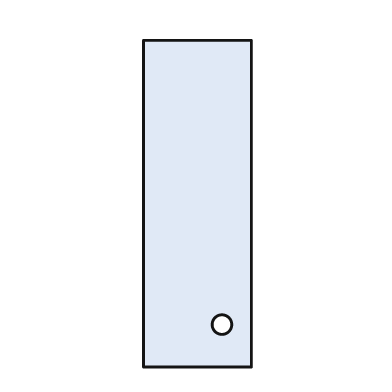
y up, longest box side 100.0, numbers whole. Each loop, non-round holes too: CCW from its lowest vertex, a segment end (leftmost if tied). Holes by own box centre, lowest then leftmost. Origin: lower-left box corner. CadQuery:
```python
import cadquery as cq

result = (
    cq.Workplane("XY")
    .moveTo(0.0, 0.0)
    .lineTo(33.0, 0.0)
    .lineTo(33.0, 100.0)
    .lineTo(0.0, 100.0)
    .close()
    .moveTo(24.0, 13.0)
    .circle(3.0)
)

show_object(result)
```